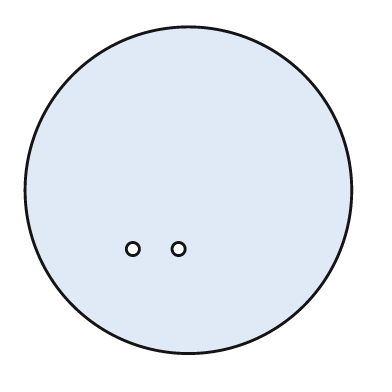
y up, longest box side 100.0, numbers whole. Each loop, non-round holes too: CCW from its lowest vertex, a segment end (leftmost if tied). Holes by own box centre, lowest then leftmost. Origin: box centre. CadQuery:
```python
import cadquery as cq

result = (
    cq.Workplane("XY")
    .moveTo(0.0, 0.0)
    .circle(50.0)
    .moveTo(-17.0, -18.0)
    .circle(2.0)
    .moveTo(-3.0, -18.0)
    .circle(2.0)
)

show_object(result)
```